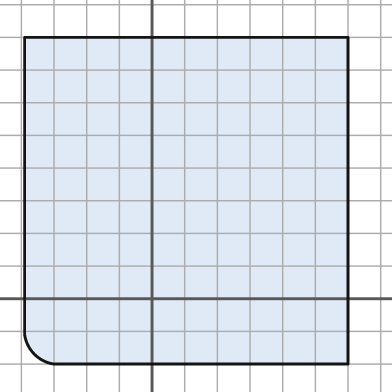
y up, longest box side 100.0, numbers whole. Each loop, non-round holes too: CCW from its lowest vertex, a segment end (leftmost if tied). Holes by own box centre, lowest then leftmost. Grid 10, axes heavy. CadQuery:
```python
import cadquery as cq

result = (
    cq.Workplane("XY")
    .moveTo(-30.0, -20.0)
    .lineTo(60.0, -20.0)
    .lineTo(60.0, 80.0)
    .lineTo(-39.0, 80.0)
    .lineTo(-39.0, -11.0)
    .threePointArc((-36.0, -17.0), (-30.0, -20.0))
    .close()
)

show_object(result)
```